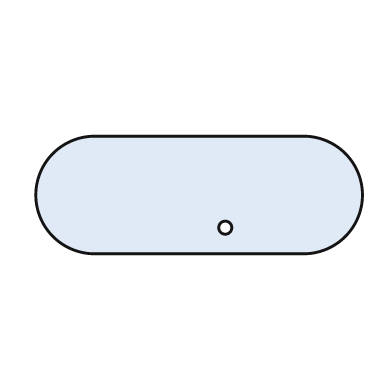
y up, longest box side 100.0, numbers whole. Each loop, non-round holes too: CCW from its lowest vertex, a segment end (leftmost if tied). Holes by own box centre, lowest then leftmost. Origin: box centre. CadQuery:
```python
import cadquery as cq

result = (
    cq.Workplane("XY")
    .moveTo(-32.0, -18.0)
    .lineTo(32.0, -18.0)
    .threePointArc((50.0, 0.0), (32.0, 18.0))
    .lineTo(-32.0, 18.0)
    .threePointArc((-50.0, 0.0), (-32.0, -18.0))
    .close()
    .moveTo(8.0, -10.0)
    .circle(2.0)
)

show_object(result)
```